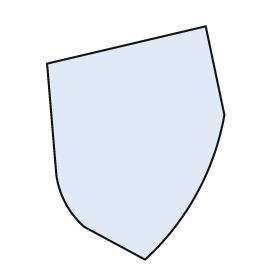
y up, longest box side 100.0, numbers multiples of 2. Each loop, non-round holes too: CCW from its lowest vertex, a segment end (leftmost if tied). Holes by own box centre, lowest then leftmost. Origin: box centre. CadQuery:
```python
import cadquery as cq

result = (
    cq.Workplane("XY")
    .moveTo(4.0, -50.0)
    .threePointArc((26.0, -22.0), (38.0, 12.0))
    .lineTo(30.0, 50.0)
    .lineTo(-38.0, 34.0)
    .lineTo(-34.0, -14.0)
    .threePointArc((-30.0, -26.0), (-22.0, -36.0))
    .close()
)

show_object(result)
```